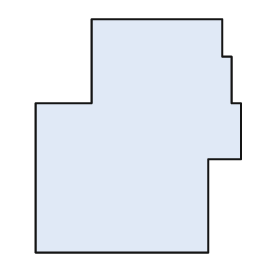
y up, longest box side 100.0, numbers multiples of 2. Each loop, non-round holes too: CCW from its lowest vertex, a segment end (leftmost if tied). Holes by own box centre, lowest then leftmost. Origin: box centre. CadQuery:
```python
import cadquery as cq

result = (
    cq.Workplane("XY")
    .moveTo(-44.0, -50.0)
    .lineTo(30.0, -50.0)
    .lineTo(30.0, -10.0)
    .lineTo(44.0, -10.0)
    .lineTo(44.0, 14.0)
    .lineTo(40.0, 14.0)
    .lineTo(40.0, 34.0)
    .lineTo(36.0, 34.0)
    .lineTo(36.0, 50.0)
    .lineTo(-20.0, 50.0)
    .lineTo(-20.0, 14.0)
    .lineTo(-44.0, 14.0)
    .close()
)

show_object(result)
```